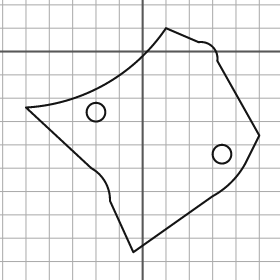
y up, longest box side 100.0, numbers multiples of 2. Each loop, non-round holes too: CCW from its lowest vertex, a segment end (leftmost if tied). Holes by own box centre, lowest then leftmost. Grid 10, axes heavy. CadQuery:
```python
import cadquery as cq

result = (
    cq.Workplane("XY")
    .moveTo(-4.0, -86.0)
    .lineTo(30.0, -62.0)
    .threePointArc((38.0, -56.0), (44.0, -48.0))
    .lineTo(50.0, -36.0)
    .lineTo(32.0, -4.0)
    .threePointArc((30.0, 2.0), (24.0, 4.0))
    .lineTo(10.0, 10.0)
    .threePointArc((-16.0, -14.0), (-50.0, -24.0))
    .lineTo(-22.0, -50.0)
    .threePointArc((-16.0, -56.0), (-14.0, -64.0))
    .close()
    .moveTo(34.0, -44.0)
    .circle(4.0)
    .moveTo(-20.0, -26.0)
    .circle(4.0)
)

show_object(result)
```